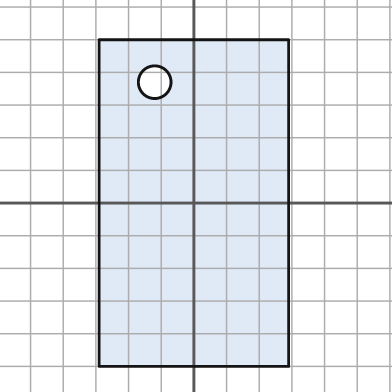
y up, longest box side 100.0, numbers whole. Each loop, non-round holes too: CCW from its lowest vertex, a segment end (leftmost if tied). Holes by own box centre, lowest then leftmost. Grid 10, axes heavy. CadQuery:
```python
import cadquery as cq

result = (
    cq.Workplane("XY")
    .moveTo(-29.0, -50.0)
    .lineTo(29.0, -50.0)
    .lineTo(29.0, 50.0)
    .lineTo(-29.0, 50.0)
    .close()
    .moveTo(-12.0, 37.0)
    .circle(5.0)
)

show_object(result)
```